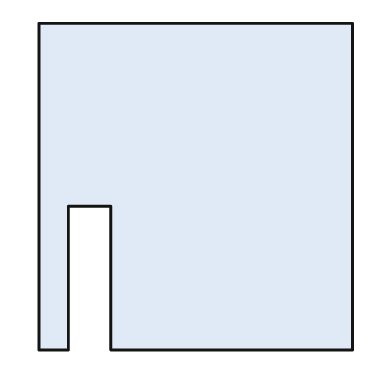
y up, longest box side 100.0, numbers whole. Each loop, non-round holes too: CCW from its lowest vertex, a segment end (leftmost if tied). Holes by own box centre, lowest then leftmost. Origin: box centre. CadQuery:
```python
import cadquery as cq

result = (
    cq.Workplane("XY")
    .moveTo(-48.0, -50.0)
    .lineTo(-39.0, -50.0)
    .lineTo(-39.0, -6.0)
    .lineTo(-26.0, -6.0)
    .lineTo(-26.0, -50.0)
    .lineTo(48.0, -50.0)
    .lineTo(48.0, 50.0)
    .lineTo(-48.0, 50.0)
    .close()
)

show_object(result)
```